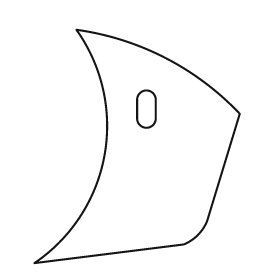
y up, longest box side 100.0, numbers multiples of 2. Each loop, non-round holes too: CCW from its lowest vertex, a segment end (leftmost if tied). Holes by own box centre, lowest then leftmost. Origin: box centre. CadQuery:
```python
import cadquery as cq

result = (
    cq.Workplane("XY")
    .moveTo(-44.0, -50.0)
    .lineTo(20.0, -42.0)
    .threePointArc((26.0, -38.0), (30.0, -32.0))
    .lineTo(44.0, 14.0)
    .threePointArc((12.0, 38.0), (-26.0, 50.0))
    .threePointArc((-14.0, -4.0), (-44.0, -50.0))
    .close()
    .moveTo(0.0, 12.0)
    .threePointArc((4.0, 8.0), (8.0, 12.0))
    .lineTo(8.0, 20.0)
    .threePointArc((4.0, 24.0), (0.0, 20.0))
    .close()
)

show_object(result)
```